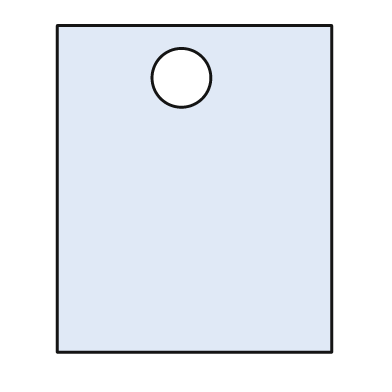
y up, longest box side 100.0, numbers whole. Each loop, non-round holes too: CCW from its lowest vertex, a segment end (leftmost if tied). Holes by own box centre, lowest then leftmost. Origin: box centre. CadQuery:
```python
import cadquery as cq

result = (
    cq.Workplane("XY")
    .moveTo(-42.0, -50.0)
    .lineTo(42.0, -50.0)
    .lineTo(42.0, 50.0)
    .lineTo(-42.0, 50.0)
    .close()
    .moveTo(-4.0, 34.0)
    .circle(9.0)
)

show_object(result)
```